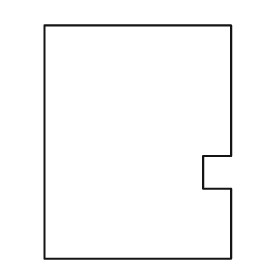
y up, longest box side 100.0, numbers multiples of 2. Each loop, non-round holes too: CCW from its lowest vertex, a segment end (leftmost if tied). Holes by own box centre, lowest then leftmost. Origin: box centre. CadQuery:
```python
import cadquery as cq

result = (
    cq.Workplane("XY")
    .moveTo(-40.0, -50.0)
    .lineTo(40.0, -50.0)
    .lineTo(40.0, -20.0)
    .lineTo(28.0, -20.0)
    .lineTo(28.0, -6.0)
    .lineTo(40.0, -6.0)
    .lineTo(40.0, 50.0)
    .lineTo(-40.0, 50.0)
    .close()
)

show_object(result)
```